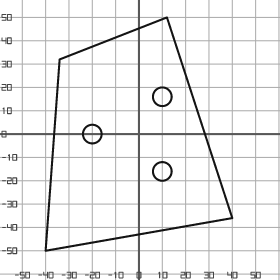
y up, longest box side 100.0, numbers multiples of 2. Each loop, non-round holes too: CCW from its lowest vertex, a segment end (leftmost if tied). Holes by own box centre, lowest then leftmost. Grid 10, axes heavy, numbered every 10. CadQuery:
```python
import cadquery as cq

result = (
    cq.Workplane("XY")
    .moveTo(-40.0, -50.0)
    .lineTo(40.0, -36.0)
    .lineTo(12.0, 50.0)
    .lineTo(-34.0, 32.0)
    .close()
    .moveTo(10.0, -16.0)
    .circle(4.0)
    .moveTo(-20.0, 0.0)
    .circle(4.0)
    .moveTo(10.0, 16.0)
    .circle(4.0)
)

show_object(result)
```